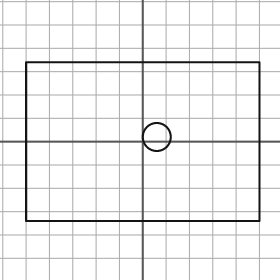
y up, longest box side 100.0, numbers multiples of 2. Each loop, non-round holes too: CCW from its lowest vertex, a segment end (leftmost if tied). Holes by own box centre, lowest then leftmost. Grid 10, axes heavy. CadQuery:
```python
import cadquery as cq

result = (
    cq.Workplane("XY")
    .moveTo(-50.0, -34.0)
    .lineTo(50.0, -34.0)
    .lineTo(50.0, 34.0)
    .lineTo(-50.0, 34.0)
    .close()
    .moveTo(6.0, 2.0)
    .circle(6.0)
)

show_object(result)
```